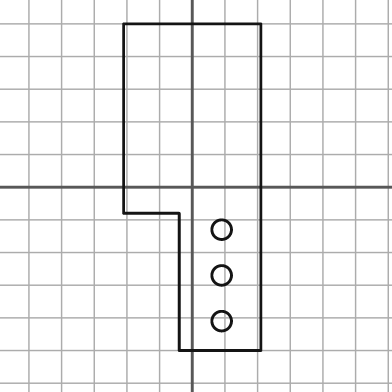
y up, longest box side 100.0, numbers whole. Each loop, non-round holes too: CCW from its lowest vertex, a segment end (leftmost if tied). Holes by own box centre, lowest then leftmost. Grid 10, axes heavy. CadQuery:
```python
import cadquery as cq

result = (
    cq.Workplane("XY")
    .moveTo(-4.0, -50.0)
    .lineTo(21.0, -50.0)
    .lineTo(21.0, 50.0)
    .lineTo(-21.0, 50.0)
    .lineTo(-21.0, -8.0)
    .lineTo(-4.0, -8.0)
    .close()
    .moveTo(9.0, -41.0)
    .circle(3.0)
    .moveTo(9.0, -27.0)
    .circle(3.0)
    .moveTo(9.0, -13.0)
    .circle(3.0)
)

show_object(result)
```